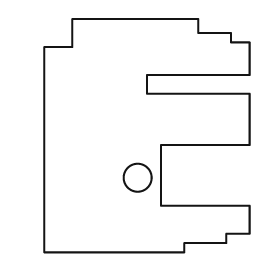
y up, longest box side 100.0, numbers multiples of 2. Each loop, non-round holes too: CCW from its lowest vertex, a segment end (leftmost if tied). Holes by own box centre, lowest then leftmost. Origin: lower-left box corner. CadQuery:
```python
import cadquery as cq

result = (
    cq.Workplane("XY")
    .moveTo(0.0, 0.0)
    .lineTo(60.0, 0.0)
    .lineTo(60.0, 4.0)
    .lineTo(78.0, 4.0)
    .lineTo(78.0, 8.0)
    .lineTo(88.0, 8.0)
    .lineTo(88.0, 20.0)
    .lineTo(50.0, 20.0)
    .lineTo(50.0, 46.0)
    .lineTo(88.0, 46.0)
    .lineTo(88.0, 68.0)
    .lineTo(44.0, 68.0)
    .lineTo(44.0, 76.0)
    .lineTo(88.0, 76.0)
    .lineTo(88.0, 90.0)
    .lineTo(80.0, 90.0)
    .lineTo(80.0, 94.0)
    .lineTo(66.0, 94.0)
    .lineTo(66.0, 100.0)
    .lineTo(12.0, 100.0)
    .lineTo(12.0, 88.0)
    .lineTo(0.0, 88.0)
    .close()
    .moveTo(40.0, 32.0)
    .circle(6.0)
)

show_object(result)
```